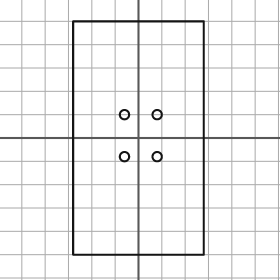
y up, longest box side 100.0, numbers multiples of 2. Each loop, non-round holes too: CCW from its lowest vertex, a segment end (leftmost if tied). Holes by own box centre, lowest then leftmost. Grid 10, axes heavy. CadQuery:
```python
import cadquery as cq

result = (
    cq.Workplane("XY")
    .moveTo(-28.0, -50.0)
    .lineTo(28.0, -50.0)
    .lineTo(28.0, 50.0)
    .lineTo(-28.0, 50.0)
    .close()
    .moveTo(-6.0, -8.0)
    .circle(2.0)
    .moveTo(8.0, -8.0)
    .circle(2.0)
    .moveTo(-6.0, 10.0)
    .circle(2.0)
    .moveTo(8.0, 10.0)
    .circle(2.0)
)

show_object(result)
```